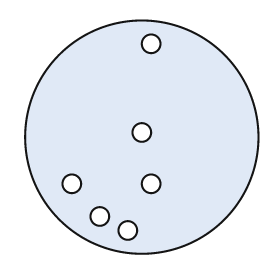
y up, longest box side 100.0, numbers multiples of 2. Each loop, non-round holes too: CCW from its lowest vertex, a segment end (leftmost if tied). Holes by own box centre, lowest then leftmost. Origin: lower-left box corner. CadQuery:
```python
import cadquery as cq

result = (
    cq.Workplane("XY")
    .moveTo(50.0, 50.0)
    .circle(50.0)
    .moveTo(44.0, 10.0)
    .circle(4.0)
    .moveTo(32.0, 16.0)
    .circle(4.0)
    .moveTo(20.0, 30.0)
    .circle(4.0)
    .moveTo(54.0, 30.0)
    .circle(4.0)
    .moveTo(50.0, 52.0)
    .circle(4.0)
    .moveTo(54.0, 90.0)
    .circle(4.0)
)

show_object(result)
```